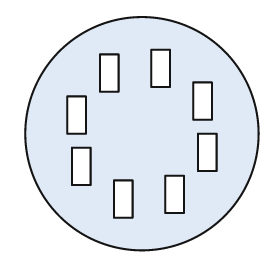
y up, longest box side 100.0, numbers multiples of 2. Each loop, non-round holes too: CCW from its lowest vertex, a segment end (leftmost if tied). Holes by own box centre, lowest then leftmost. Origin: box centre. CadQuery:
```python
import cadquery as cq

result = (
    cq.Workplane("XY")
    .moveTo(0.0, 0.0)
    .circle(50.0)
    .moveTo(-12.0, -36.0)
    .lineTo(-4.0, -36.0)
    .lineTo(-4.0, -20.0)
    .lineTo(-12.0, -20.0)
    .close()
    .moveTo(10.0, -34.0)
    .lineTo(18.0, -34.0)
    .lineTo(18.0, -18.0)
    .lineTo(10.0, -18.0)
    .close()
    .moveTo(-30.0, -22.0)
    .lineTo(-22.0, -22.0)
    .lineTo(-22.0, -6.0)
    .lineTo(-30.0, -6.0)
    .close()
    .moveTo(24.0, -16.0)
    .lineTo(32.0, -16.0)
    .lineTo(32.0, 0.0)
    .lineTo(24.0, 0.0)
    .close()
    .moveTo(-32.0, 0.0)
    .lineTo(-24.0, 0.0)
    .lineTo(-24.0, 16.0)
    .lineTo(-32.0, 16.0)
    .close()
    .moveTo(22.0, 6.0)
    .lineTo(30.0, 6.0)
    .lineTo(30.0, 22.0)
    .lineTo(22.0, 22.0)
    .close()
    .moveTo(-18.0, 18.0)
    .lineTo(-10.0, 18.0)
    .lineTo(-10.0, 34.0)
    .lineTo(-18.0, 34.0)
    .close()
    .moveTo(4.0, 20.0)
    .lineTo(12.0, 20.0)
    .lineTo(12.0, 36.0)
    .lineTo(4.0, 36.0)
    .close()
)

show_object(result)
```